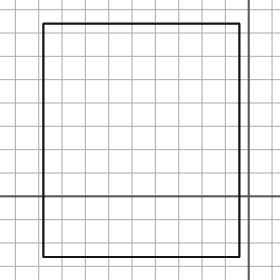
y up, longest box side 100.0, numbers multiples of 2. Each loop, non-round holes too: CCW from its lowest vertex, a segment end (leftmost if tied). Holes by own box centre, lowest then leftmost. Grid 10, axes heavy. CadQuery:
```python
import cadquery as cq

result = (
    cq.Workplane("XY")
    .moveTo(-88.0, -26.0)
    .lineTo(-4.0, -26.0)
    .lineTo(-4.0, 74.0)
    .lineTo(-88.0, 74.0)
    .close()
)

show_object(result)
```